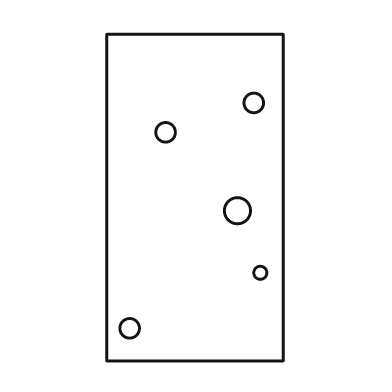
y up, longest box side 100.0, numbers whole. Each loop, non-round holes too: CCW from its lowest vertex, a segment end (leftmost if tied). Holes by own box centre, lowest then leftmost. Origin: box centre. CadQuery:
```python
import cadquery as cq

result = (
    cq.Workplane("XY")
    .moveTo(-27.0, -50.0)
    .lineTo(27.0, -50.0)
    .lineTo(27.0, 50.0)
    .lineTo(-27.0, 50.0)
    .close()
    .moveTo(-20.0, -40.0)
    .circle(3.0)
    .moveTo(20.0, -23.0)
    .circle(2.0)
    .moveTo(13.0, -4.0)
    .circle(4.0)
    .moveTo(-9.0, 20.0)
    .circle(3.0)
    .moveTo(18.0, 29.0)
    .circle(3.0)
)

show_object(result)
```